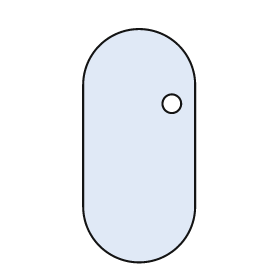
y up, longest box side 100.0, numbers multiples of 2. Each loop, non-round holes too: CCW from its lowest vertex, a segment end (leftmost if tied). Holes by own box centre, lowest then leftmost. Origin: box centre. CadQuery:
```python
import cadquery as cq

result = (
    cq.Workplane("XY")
    .moveTo(-24.0, -26.0)
    .threePointArc((0.0, -50.0), (24.0, -26.0))
    .lineTo(24.0, 26.0)
    .threePointArc((0.0, 50.0), (-24.0, 26.0))
    .close()
    .moveTo(14.0, 18.0)
    .circle(4.0)
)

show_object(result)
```